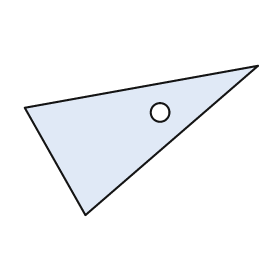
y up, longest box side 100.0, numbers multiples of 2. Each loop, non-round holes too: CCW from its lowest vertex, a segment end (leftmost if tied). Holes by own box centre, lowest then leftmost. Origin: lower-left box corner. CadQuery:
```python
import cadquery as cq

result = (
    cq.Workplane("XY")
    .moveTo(26.0, 0.0)
    .lineTo(100.0, 64.0)
    .lineTo(0.0, 46.0)
    .close()
    .moveTo(58.0, 44.0)
    .circle(4.0)
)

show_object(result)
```